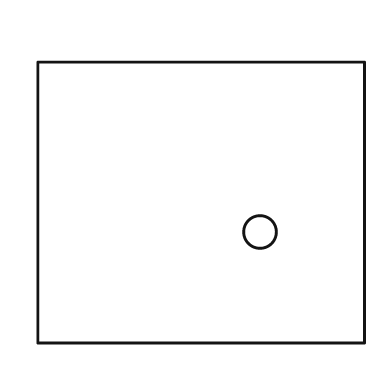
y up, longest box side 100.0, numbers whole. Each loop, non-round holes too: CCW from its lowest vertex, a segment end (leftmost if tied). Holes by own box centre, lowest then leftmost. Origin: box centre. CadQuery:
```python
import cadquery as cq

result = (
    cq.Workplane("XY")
    .moveTo(-50.0, -43.0)
    .lineTo(50.0, -43.0)
    .lineTo(50.0, 43.0)
    .lineTo(-50.0, 43.0)
    .close()
    .moveTo(18.0, -9.0)
    .circle(5.0)
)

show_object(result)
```